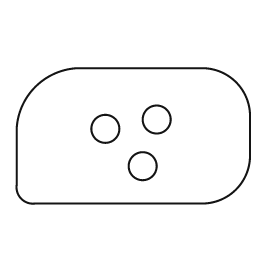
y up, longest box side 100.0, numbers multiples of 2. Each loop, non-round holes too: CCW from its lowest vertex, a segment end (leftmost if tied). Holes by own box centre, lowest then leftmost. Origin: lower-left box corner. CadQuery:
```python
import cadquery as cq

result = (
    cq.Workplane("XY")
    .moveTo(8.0, 0.0)
    .lineTo(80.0, 0.0)
    .threePointArc((94.0, 6.0), (100.0, 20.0))
    .lineTo(100.0, 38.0)
    .threePointArc((94.0, 52.0), (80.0, 58.0))
    .lineTo(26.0, 58.0)
    .threePointArc((8.0, 50.0), (0.0, 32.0))
    .lineTo(0.0, 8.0)
    .threePointArc((2.0, 2.0), (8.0, 0.0))
    .close()
    .moveTo(54.0, 16.0)
    .circle(6.0)
    .moveTo(38.0, 32.0)
    .circle(6.0)
    .moveTo(60.0, 36.0)
    .circle(6.0)
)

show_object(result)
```